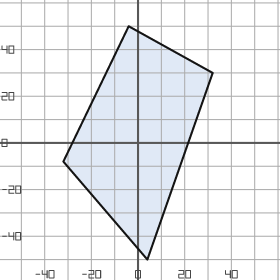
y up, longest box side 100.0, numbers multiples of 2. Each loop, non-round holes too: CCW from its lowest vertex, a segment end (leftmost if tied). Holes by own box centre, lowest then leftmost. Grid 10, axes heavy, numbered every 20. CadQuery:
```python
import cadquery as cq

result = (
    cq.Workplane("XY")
    .moveTo(4.0, -50.0)
    .lineTo(32.0, 30.0)
    .lineTo(-4.0, 50.0)
    .lineTo(-32.0, -8.0)
    .close()
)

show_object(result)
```